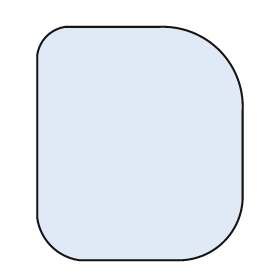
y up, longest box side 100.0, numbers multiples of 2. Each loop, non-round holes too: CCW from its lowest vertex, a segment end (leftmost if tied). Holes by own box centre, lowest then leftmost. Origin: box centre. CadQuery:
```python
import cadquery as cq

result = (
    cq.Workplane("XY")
    .moveTo(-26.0, -50.0)
    .lineTo(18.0, -50.0)
    .threePointArc((36.0, -42.0), (44.0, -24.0))
    .lineTo(44.0, 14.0)
    .threePointArc((34.0, 40.0), (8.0, 50.0))
    .lineTo(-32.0, 50.0)
    .threePointArc((-40.0, 46.0), (-44.0, 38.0))
    .lineTo(-44.0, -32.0)
    .threePointArc((-38.0, -44.0), (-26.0, -50.0))
    .close()
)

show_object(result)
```